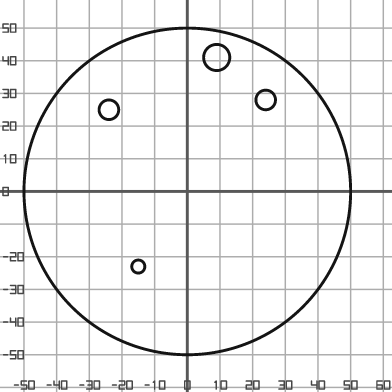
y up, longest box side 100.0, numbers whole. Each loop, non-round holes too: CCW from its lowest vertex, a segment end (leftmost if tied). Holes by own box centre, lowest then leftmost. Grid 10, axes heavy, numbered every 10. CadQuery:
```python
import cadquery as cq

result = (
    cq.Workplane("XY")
    .moveTo(0.0, 0.0)
    .circle(50.0)
    .moveTo(-15.0, -23.0)
    .circle(2.0)
    .moveTo(-24.0, 25.0)
    .circle(3.0)
    .moveTo(24.0, 28.0)
    .circle(3.0)
    .moveTo(9.0, 41.0)
    .circle(4.0)
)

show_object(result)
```